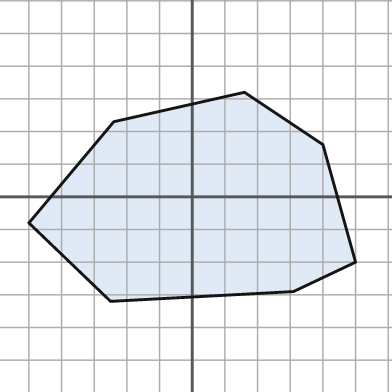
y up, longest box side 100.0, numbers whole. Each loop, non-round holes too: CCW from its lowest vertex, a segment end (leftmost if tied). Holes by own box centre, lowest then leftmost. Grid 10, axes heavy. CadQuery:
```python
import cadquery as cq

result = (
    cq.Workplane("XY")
    .moveTo(-25.0, -32.0)
    .lineTo(31.0, -29.0)
    .lineTo(50.0, -20.0)
    .lineTo(40.0, 16.0)
    .lineTo(16.0, 32.0)
    .lineTo(-24.0, 23.0)
    .lineTo(-50.0, -8.0)
    .close()
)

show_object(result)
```